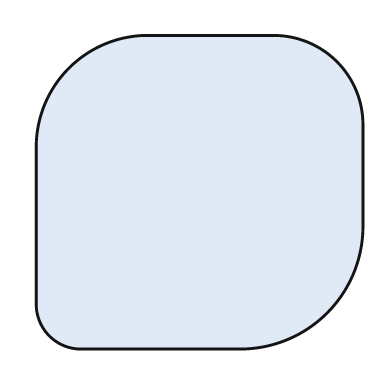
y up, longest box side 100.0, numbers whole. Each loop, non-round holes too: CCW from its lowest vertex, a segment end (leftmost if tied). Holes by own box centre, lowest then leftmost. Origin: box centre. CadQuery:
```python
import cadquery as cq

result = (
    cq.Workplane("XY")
    .moveTo(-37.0, -48.0)
    .lineTo(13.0, -48.0)
    .threePointArc((39.0, -37.0), (50.0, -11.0))
    .lineTo(50.0, 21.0)
    .threePointArc((42.0, 40.0), (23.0, 48.0))
    .lineTo(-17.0, 48.0)
    .threePointArc((-40.0, 38.0), (-50.0, 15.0))
    .lineTo(-50.0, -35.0)
    .threePointArc((-46.0, -44.0), (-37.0, -48.0))
    .close()
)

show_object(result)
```